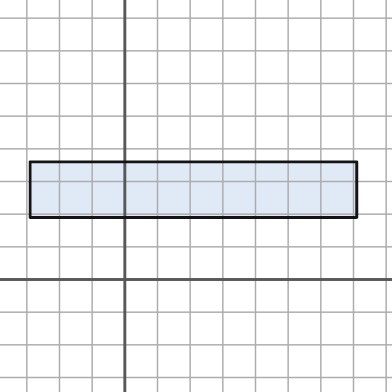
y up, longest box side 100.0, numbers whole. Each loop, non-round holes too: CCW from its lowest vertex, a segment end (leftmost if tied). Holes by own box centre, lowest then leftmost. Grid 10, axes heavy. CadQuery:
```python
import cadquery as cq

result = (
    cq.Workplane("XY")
    .moveTo(-29.0, 19.0)
    .lineTo(71.0, 19.0)
    .lineTo(71.0, 36.0)
    .lineTo(-29.0, 36.0)
    .close()
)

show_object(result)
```